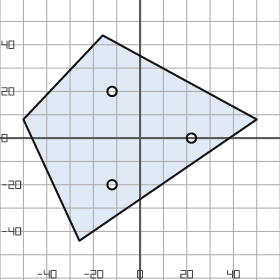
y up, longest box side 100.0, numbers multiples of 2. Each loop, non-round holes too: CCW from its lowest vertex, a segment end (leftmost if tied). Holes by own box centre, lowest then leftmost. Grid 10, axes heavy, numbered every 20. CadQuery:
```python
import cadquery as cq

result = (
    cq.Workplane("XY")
    .moveTo(-26.0, -44.0)
    .lineTo(50.0, 8.0)
    .lineTo(-16.0, 44.0)
    .lineTo(-50.0, 8.0)
    .close()
    .moveTo(-12.0, -20.0)
    .circle(2.0)
    .moveTo(22.0, 0.0)
    .circle(2.0)
    .moveTo(-12.0, 20.0)
    .circle(2.0)
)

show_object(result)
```